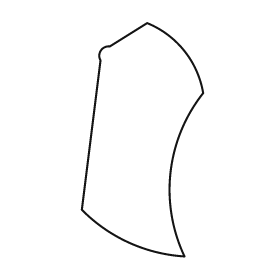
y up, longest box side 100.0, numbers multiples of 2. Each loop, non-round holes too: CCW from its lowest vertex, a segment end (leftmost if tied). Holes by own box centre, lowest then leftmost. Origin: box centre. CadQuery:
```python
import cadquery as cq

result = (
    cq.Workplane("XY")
    .moveTo(18.0, -50.0)
    .threePointArc((12.0, -14.0), (26.0, 20.0))
    .threePointArc((18.0, 38.0), (2.0, 50.0))
    .lineTo(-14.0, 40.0)
    .threePointArc((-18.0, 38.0), (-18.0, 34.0))
    .lineTo(-26.0, -30.0)
    .threePointArc((-6.0, -44.0), (18.0, -50.0))
    .close()
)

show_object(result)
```